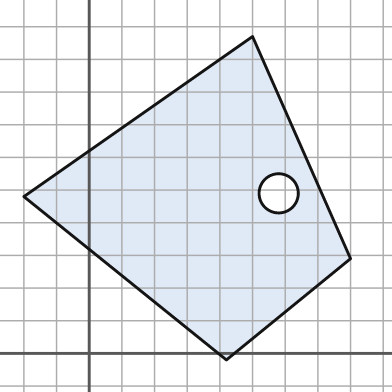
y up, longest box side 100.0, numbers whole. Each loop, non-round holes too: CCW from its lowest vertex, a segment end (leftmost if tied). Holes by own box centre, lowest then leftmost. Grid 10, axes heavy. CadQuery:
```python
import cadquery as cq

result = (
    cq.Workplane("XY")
    .moveTo(42.0, -2.0)
    .lineTo(80.0, 29.0)
    .lineTo(50.0, 97.0)
    .lineTo(-20.0, 48.0)
    .close()
    .moveTo(58.0, 49.0)
    .circle(6.0)
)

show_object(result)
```